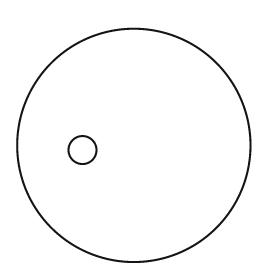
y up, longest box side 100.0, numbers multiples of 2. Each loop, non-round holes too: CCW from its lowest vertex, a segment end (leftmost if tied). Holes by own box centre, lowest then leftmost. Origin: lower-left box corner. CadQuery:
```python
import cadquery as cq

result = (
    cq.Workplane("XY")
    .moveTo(50.0, 50.0)
    .circle(50.0)
    .moveTo(28.0, 48.0)
    .circle(6.0)
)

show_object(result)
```